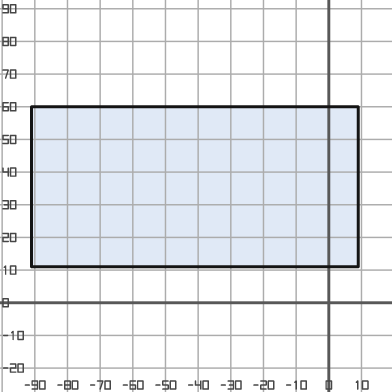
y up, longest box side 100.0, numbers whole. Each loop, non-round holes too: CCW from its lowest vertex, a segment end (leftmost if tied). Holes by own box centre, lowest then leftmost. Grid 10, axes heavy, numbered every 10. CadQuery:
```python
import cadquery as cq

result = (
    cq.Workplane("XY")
    .moveTo(-91.0, 11.0)
    .lineTo(9.0, 11.0)
    .lineTo(9.0, 60.0)
    .lineTo(-91.0, 60.0)
    .close()
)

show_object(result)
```